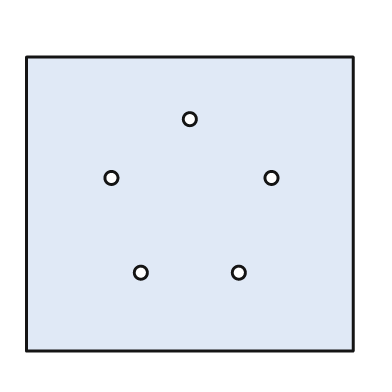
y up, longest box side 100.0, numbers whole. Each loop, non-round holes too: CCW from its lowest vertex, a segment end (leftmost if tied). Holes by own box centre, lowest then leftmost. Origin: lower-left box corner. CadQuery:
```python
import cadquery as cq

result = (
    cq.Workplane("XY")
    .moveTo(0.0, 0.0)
    .lineTo(100.0, 0.0)
    .lineTo(100.0, 90.0)
    .lineTo(0.0, 90.0)
    .close()
    .moveTo(35.0, 24.0)
    .circle(2.0)
    .moveTo(65.0, 24.0)
    .circle(2.0)
    .moveTo(26.0, 53.0)
    .circle(2.0)
    .moveTo(75.0, 53.0)
    .circle(2.0)
    .moveTo(50.0, 71.0)
    .circle(2.0)
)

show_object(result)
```